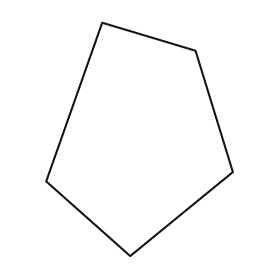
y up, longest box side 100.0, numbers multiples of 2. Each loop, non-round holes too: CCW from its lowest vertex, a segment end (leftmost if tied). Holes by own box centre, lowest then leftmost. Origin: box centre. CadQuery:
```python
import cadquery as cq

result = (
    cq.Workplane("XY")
    .moveTo(-4.0, -50.0)
    .lineTo(40.0, -14.0)
    .lineTo(24.0, 38.0)
    .lineTo(-16.0, 50.0)
    .lineTo(-40.0, -18.0)
    .close()
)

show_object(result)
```